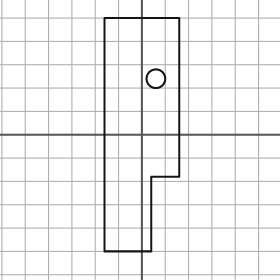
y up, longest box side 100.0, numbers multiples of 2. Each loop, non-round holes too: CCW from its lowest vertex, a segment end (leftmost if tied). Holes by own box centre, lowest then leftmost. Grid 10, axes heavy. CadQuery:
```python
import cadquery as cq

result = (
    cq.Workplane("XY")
    .moveTo(-16.0, -50.0)
    .lineTo(4.0, -50.0)
    .lineTo(4.0, -18.0)
    .lineTo(16.0, -18.0)
    .lineTo(16.0, 50.0)
    .lineTo(-16.0, 50.0)
    .close()
    .moveTo(6.0, 24.0)
    .circle(4.0)
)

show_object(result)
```